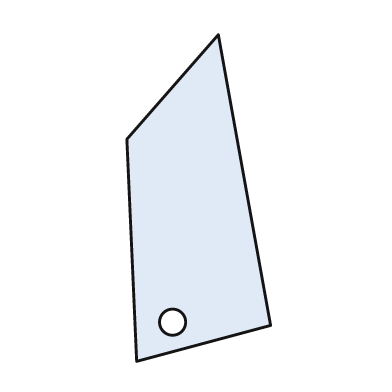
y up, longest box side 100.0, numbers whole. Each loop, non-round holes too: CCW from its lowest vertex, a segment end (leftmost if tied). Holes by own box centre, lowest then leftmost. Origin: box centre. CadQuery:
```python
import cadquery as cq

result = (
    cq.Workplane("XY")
    .moveTo(-19.0, -50.0)
    .lineTo(22.0, -39.0)
    .lineTo(6.0, 50.0)
    .lineTo(-22.0, 18.0)
    .close()
    .moveTo(-8.0, -38.0)
    .circle(4.0)
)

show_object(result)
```